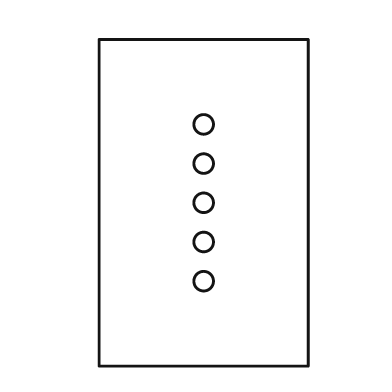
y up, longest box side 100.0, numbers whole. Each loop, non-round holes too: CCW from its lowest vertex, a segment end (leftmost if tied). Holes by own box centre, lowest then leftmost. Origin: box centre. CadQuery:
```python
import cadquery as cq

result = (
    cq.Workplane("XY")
    .moveTo(-32.0, -50.0)
    .lineTo(32.0, -50.0)
    .lineTo(32.0, 50.0)
    .lineTo(-32.0, 50.0)
    .close()
    .moveTo(0.0, -24.0)
    .circle(3.0)
    .moveTo(0.0, -12.0)
    .circle(3.0)
    .moveTo(0.0, 0.0)
    .circle(3.0)
    .moveTo(0.0, 12.0)
    .circle(3.0)
    .moveTo(0.0, 24.0)
    .circle(3.0)
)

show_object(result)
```